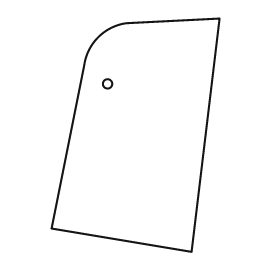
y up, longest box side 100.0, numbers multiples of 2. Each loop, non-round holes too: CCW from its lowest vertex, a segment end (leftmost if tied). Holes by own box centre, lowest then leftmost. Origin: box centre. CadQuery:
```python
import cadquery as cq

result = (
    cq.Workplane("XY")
    .moveTo(24.0, -50.0)
    .lineTo(36.0, 50.0)
    .lineTo(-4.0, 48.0)
    .threePointArc((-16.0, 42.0), (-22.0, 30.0))
    .lineTo(-36.0, -40.0)
    .close()
    .moveTo(-12.0, 22.0)
    .circle(2.0)
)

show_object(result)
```